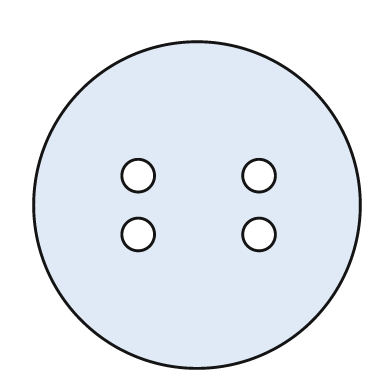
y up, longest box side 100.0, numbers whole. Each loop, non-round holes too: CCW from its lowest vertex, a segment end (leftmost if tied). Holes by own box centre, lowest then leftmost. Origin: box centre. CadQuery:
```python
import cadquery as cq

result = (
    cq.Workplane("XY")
    .moveTo(0.0, 0.0)
    .circle(50.0)
    .moveTo(-18.0, -9.0)
    .circle(5.0)
    .moveTo(19.0, -9.0)
    .circle(5.0)
    .moveTo(-18.0, 9.0)
    .circle(5.0)
    .moveTo(19.0, 9.0)
    .circle(5.0)
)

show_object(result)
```